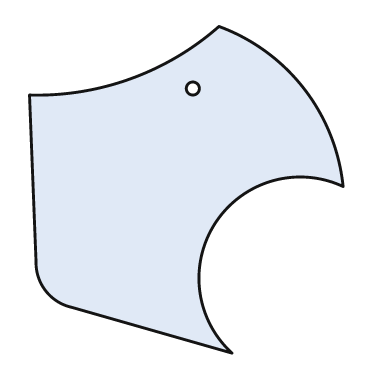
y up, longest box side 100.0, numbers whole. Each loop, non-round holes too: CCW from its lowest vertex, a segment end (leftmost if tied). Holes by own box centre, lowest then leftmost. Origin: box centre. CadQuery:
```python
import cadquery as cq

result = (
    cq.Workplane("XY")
    .moveTo(14.0, -50.0)
    .threePointArc((9.0, -10.0), (48.0, 1.0))
    .threePointArc((36.0, 31.0), (10.0, 50.0))
    .threePointArc((-17.0, 34.0), (-48.0, 29.0))
    .lineTo(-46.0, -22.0)
    .threePointArc((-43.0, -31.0), (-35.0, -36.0))
    .close()
    .moveTo(2.0, 31.0)
    .circle(2.0)
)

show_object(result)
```